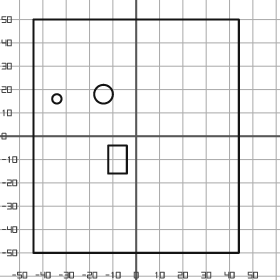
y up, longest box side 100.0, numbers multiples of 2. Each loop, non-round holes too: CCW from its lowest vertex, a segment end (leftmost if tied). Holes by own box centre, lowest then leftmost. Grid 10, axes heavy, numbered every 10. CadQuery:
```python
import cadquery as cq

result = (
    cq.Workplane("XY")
    .moveTo(-44.0, -50.0)
    .lineTo(44.0, -50.0)
    .lineTo(44.0, 50.0)
    .lineTo(-44.0, 50.0)
    .close()
    .moveTo(-12.0, -16.0)
    .lineTo(-4.0, -16.0)
    .lineTo(-4.0, -4.0)
    .lineTo(-12.0, -4.0)
    .close()
    .moveTo(-34.0, 16.0)
    .circle(2.0)
    .moveTo(-14.0, 18.0)
    .circle(4.0)
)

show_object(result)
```